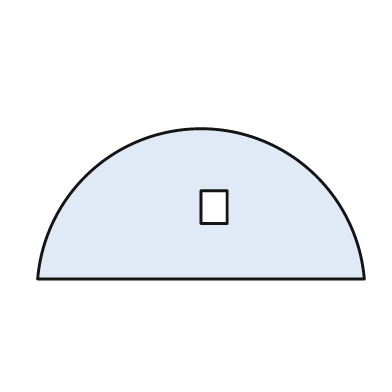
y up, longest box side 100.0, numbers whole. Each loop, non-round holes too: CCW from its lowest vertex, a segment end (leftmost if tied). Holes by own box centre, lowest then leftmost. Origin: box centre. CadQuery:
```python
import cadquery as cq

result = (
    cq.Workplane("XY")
    .moveTo(-50.0, -23.0)
    .lineTo(50.0, -23.0)
    .threePointArc((0.0, 23.0), (-50.0, -23.0))
    .close()
    .moveTo(0.0, -6.0)
    .lineTo(8.0, -6.0)
    .lineTo(8.0, 4.0)
    .lineTo(0.0, 4.0)
    .close()
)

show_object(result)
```